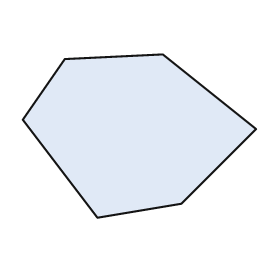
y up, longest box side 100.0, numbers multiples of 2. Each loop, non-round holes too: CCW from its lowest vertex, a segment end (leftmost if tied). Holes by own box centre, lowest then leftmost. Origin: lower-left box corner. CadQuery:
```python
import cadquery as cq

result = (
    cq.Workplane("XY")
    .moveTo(32.0, 0.0)
    .lineTo(68.0, 6.0)
    .lineTo(100.0, 38.0)
    .lineTo(60.0, 70.0)
    .lineTo(18.0, 68.0)
    .lineTo(0.0, 42.0)
    .close()
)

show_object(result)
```